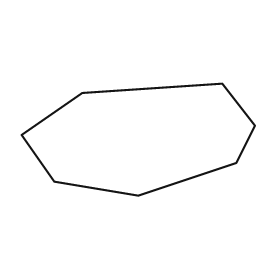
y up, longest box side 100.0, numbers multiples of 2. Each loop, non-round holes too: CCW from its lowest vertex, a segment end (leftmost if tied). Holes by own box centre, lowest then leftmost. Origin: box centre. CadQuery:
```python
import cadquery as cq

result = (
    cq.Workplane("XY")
    .moveTo(0.0, -24.0)
    .lineTo(42.0, -10.0)
    .lineTo(50.0, 6.0)
    .lineTo(36.0, 24.0)
    .lineTo(-24.0, 20.0)
    .lineTo(-50.0, 2.0)
    .lineTo(-36.0, -18.0)
    .close()
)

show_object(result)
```